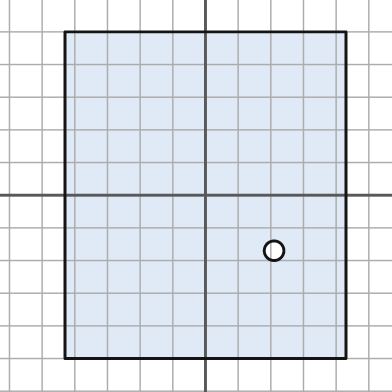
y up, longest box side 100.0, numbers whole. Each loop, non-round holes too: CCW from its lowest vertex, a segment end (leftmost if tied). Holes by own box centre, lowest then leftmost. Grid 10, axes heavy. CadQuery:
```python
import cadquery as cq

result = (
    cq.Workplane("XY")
    .moveTo(-43.0, -50.0)
    .lineTo(43.0, -50.0)
    .lineTo(43.0, 50.0)
    .lineTo(-43.0, 50.0)
    .close()
    .moveTo(21.0, -17.0)
    .circle(3.0)
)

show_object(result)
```